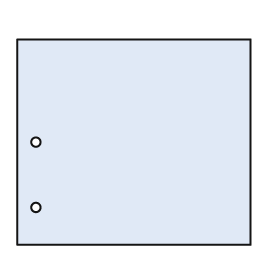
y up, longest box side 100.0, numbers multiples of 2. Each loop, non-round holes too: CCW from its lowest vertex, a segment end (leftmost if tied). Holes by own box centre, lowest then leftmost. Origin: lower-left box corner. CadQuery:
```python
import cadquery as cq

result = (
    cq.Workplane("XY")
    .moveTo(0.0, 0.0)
    .lineTo(100.0, 0.0)
    .lineTo(100.0, 88.0)
    .lineTo(0.0, 88.0)
    .close()
    .moveTo(8.0, 16.0)
    .circle(2.0)
    .moveTo(8.0, 44.0)
    .circle(2.0)
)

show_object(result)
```